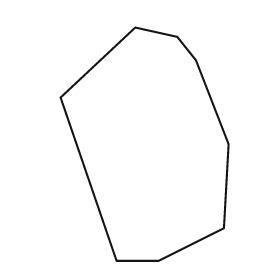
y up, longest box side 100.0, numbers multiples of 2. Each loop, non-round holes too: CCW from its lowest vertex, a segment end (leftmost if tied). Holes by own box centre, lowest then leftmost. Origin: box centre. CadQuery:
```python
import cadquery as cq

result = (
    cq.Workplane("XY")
    .moveTo(-12.0, -50.0)
    .lineTo(6.0, -50.0)
    .lineTo(34.0, -36.0)
    .lineTo(36.0, 0.0)
    .lineTo(22.0, 36.0)
    .lineTo(14.0, 46.0)
    .lineTo(-4.0, 50.0)
    .lineTo(-36.0, 20.0)
    .close()
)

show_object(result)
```